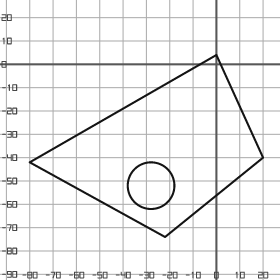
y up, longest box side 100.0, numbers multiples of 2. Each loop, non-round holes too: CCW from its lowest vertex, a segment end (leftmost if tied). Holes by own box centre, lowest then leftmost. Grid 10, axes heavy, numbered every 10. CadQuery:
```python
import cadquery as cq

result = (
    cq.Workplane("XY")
    .moveTo(-22.0, -74.0)
    .lineTo(20.0, -40.0)
    .lineTo(0.0, 4.0)
    .lineTo(-80.0, -42.0)
    .close()
    .moveTo(-28.0, -52.0)
    .circle(10.0)
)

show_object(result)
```